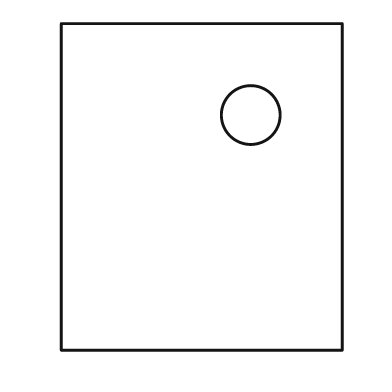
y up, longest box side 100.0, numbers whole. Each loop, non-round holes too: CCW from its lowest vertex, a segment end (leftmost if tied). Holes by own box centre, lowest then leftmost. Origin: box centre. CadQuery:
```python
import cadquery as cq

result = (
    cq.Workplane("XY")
    .moveTo(-43.0, -50.0)
    .lineTo(43.0, -50.0)
    .lineTo(43.0, 50.0)
    .lineTo(-43.0, 50.0)
    .close()
    .moveTo(15.0, 22.0)
    .circle(9.0)
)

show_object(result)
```